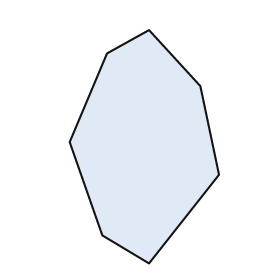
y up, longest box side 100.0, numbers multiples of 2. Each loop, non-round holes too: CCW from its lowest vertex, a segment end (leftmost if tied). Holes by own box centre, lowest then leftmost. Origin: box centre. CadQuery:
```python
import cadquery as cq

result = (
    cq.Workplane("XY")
    .moveTo(2.0, -50.0)
    .lineTo(32.0, -12.0)
    .lineTo(24.0, 26.0)
    .lineTo(2.0, 50.0)
    .lineTo(-16.0, 40.0)
    .lineTo(-32.0, 2.0)
    .lineTo(-18.0, -38.0)
    .close()
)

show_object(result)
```